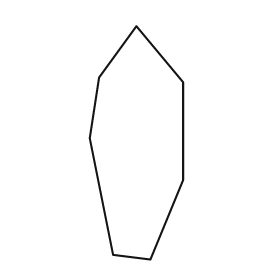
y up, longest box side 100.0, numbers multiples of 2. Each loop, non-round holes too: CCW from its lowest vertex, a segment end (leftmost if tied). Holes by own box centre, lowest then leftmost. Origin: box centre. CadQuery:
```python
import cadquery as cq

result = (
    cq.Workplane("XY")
    .moveTo(6.0, -50.0)
    .lineTo(20.0, -16.0)
    .lineTo(20.0, 26.0)
    .lineTo(0.0, 50.0)
    .lineTo(-16.0, 28.0)
    .lineTo(-20.0, 2.0)
    .lineTo(-10.0, -48.0)
    .close()
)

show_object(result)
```